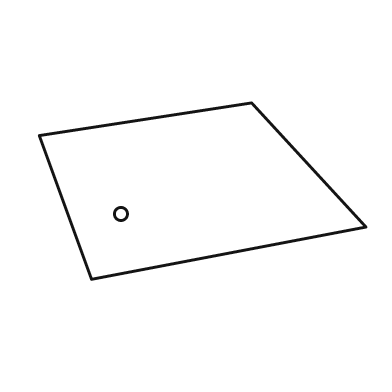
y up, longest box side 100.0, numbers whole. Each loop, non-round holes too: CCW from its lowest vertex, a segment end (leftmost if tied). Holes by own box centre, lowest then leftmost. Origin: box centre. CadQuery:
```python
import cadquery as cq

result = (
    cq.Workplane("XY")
    .moveTo(-34.0, -27.0)
    .lineTo(50.0, -11.0)
    .lineTo(15.0, 27.0)
    .lineTo(-50.0, 17.0)
    .close()
    .moveTo(-25.0, -7.0)
    .circle(2.0)
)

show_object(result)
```